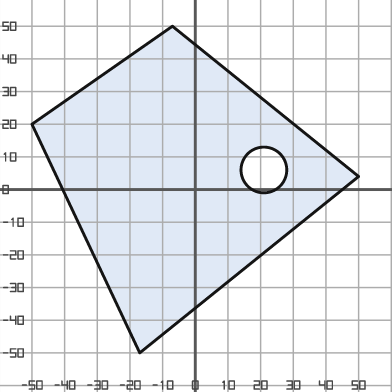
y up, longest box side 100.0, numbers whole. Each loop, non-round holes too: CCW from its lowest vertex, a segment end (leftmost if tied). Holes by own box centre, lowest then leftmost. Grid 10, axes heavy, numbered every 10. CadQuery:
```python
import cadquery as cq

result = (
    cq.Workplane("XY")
    .moveTo(-17.0, -50.0)
    .lineTo(50.0, 4.0)
    .lineTo(-7.0, 50.0)
    .lineTo(-50.0, 20.0)
    .close()
    .moveTo(21.0, 6.0)
    .circle(7.0)
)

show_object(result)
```